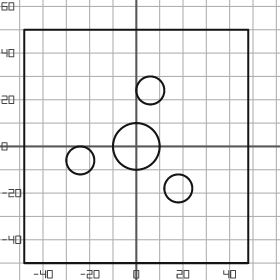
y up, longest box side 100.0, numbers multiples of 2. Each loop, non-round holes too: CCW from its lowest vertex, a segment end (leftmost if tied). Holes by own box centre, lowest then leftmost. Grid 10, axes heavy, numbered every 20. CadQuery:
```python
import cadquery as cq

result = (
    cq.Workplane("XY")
    .moveTo(-48.0, -50.0)
    .lineTo(48.0, -50.0)
    .lineTo(48.0, 50.0)
    .lineTo(-48.0, 50.0)
    .close()
    .moveTo(18.0, -18.0)
    .circle(6.0)
    .moveTo(-24.0, -6.0)
    .circle(6.0)
    .moveTo(0.0, 0.0)
    .circle(10.0)
    .moveTo(6.0, 24.0)
    .circle(6.0)
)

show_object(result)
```